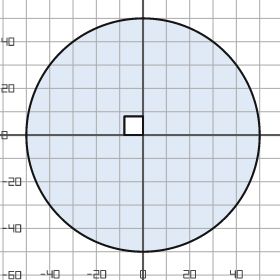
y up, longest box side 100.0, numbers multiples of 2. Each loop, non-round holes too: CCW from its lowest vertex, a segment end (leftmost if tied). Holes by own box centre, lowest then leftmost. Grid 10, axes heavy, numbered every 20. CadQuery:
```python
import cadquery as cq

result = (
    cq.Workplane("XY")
    .moveTo(0.0, 0.0)
    .circle(50.0)
    .moveTo(-8.0, 0.0)
    .lineTo(0.0, 0.0)
    .lineTo(0.0, 8.0)
    .lineTo(-8.0, 8.0)
    .close()
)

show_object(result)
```